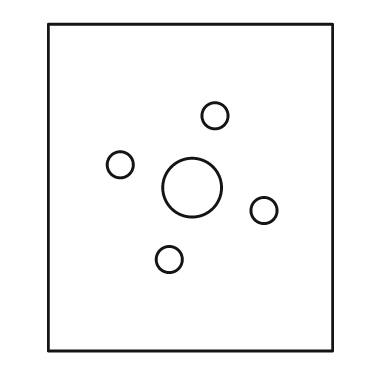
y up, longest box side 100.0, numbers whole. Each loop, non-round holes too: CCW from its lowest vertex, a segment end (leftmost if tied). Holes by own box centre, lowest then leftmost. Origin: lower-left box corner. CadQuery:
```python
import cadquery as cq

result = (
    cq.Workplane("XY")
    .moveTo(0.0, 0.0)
    .lineTo(87.0, 0.0)
    .lineTo(87.0, 100.0)
    .lineTo(0.0, 100.0)
    .close()
    .moveTo(37.0, 28.0)
    .circle(4.0)
    .moveTo(66.0, 43.0)
    .circle(4.0)
    .moveTo(44.0, 50.0)
    .circle(9.0)
    .moveTo(22.0, 57.0)
    .circle(4.0)
    .moveTo(51.0, 72.0)
    .circle(4.0)
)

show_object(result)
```